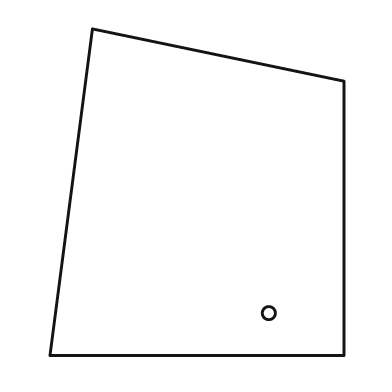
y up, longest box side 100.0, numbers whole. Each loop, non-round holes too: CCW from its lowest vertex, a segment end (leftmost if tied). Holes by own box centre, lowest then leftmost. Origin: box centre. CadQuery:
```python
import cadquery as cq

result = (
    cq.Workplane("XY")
    .moveTo(-45.0, -50.0)
    .lineTo(45.0, -50.0)
    .lineTo(45.0, 34.0)
    .lineTo(-32.0, 50.0)
    .close()
    .moveTo(22.0, -37.0)
    .circle(2.0)
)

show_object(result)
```